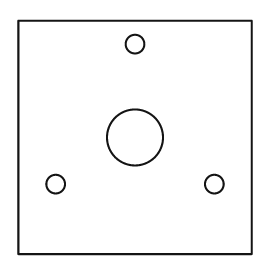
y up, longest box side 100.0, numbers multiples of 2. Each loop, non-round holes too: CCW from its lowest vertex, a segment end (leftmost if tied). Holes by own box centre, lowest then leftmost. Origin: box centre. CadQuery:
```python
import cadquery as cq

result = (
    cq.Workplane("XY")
    .moveTo(-50.0, -50.0)
    .lineTo(50.0, -50.0)
    .lineTo(50.0, 50.0)
    .lineTo(-50.0, 50.0)
    .close()
    .moveTo(-34.0, -20.0)
    .circle(4.0)
    .moveTo(34.0, -20.0)
    .circle(4.0)
    .moveTo(0.0, 0.0)
    .circle(12.0)
    .moveTo(0.0, 40.0)
    .circle(4.0)
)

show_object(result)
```